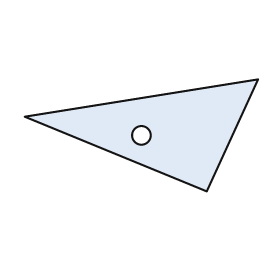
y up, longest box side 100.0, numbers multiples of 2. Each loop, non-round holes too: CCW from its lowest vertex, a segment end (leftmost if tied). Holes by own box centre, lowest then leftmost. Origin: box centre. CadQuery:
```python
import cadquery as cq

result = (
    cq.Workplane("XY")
    .moveTo(28.0, -24.0)
    .lineTo(50.0, 24.0)
    .lineTo(-50.0, 8.0)
    .close()
    .moveTo(0.0, 0.0)
    .circle(4.0)
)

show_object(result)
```